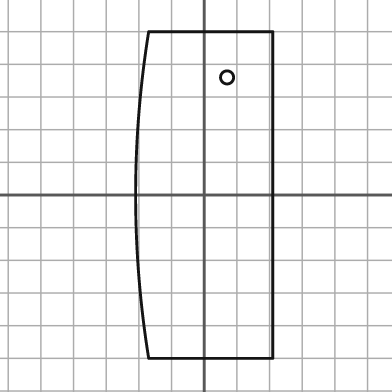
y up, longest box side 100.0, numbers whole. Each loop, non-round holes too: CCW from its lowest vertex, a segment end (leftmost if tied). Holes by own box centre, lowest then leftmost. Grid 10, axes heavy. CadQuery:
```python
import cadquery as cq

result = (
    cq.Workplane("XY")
    .moveTo(-17.0, -50.0)
    .lineTo(21.0, -50.0)
    .lineTo(21.0, 50.0)
    .lineTo(-17.0, 50.0)
    .threePointArc((-21.0, 0.0), (-17.0, -50.0))
    .close()
    .moveTo(7.0, 36.0)
    .circle(2.0)
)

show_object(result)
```